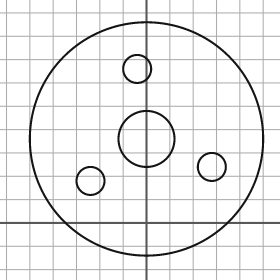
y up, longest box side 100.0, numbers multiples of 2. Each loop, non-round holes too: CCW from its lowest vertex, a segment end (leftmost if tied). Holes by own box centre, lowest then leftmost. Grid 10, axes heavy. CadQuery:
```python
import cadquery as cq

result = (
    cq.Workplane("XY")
    .moveTo(0.0, 36.0)
    .circle(50.0)
    .moveTo(-24.0, 18.0)
    .circle(6.0)
    .moveTo(28.0, 24.0)
    .circle(6.0)
    .moveTo(0.0, 36.0)
    .circle(12.0)
    .moveTo(-4.0, 66.0)
    .circle(6.0)
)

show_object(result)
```